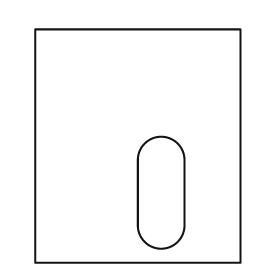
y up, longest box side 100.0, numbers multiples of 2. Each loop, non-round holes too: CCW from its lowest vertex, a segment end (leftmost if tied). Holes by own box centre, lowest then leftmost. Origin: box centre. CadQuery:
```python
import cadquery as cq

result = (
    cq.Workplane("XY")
    .moveTo(-44.0, -50.0)
    .lineTo(44.0, -50.0)
    .lineTo(44.0, 50.0)
    .lineTo(-44.0, 50.0)
    .close()
    .moveTo(0.0, -34.0)
    .threePointArc((10.0, -44.0), (20.0, -34.0))
    .lineTo(20.0, -6.0)
    .threePointArc((10.0, 4.0), (0.0, -6.0))
    .close()
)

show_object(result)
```